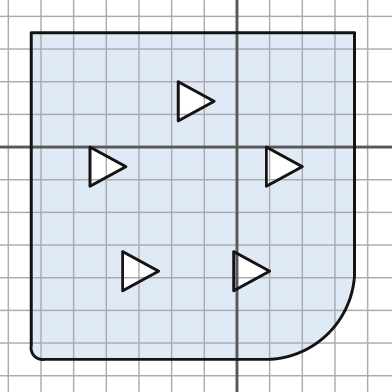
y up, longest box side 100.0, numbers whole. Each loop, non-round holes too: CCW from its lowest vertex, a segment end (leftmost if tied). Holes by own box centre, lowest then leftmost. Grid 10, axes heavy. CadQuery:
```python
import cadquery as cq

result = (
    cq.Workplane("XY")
    .moveTo(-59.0, -65.0)
    .lineTo(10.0, -65.0)
    .threePointArc((28.0, -57.0), (36.0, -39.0))
    .lineTo(36.0, 35.0)
    .lineTo(-63.0, 35.0)
    .lineTo(-63.0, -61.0)
    .threePointArc((-62.0, -64.0), (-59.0, -65.0))
    .close()
    .moveTo(-35.0, -44.0)
    .lineTo(-24.0, -38.0)
    .lineTo(-35.0, -32.0)
    .close()
    .moveTo(-1.0, -44.0)
    .lineTo(10.0, -38.0)
    .lineTo(-1.0, -32.0)
    .close()
    .moveTo(-45.0, -12.0)
    .lineTo(-34.0, -6.0)
    .lineTo(-45.0, 0.0)
    .close()
    .moveTo(9.0, -12.0)
    .lineTo(20.0, -6.0)
    .lineTo(9.0, 0.0)
    .close()
    .moveTo(-18.0, 8.0)
    .lineTo(-7.0, 14.0)
    .lineTo(-18.0, 20.0)
    .close()
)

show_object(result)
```